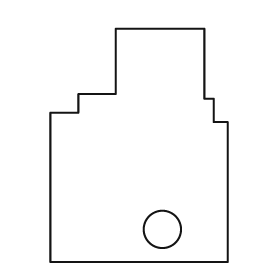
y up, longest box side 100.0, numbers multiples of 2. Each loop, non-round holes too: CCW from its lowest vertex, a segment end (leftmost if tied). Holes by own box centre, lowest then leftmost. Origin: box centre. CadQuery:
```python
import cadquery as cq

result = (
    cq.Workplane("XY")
    .moveTo(-38.0, -50.0)
    .lineTo(38.0, -50.0)
    .lineTo(38.0, 10.0)
    .lineTo(32.0, 10.0)
    .lineTo(32.0, 20.0)
    .lineTo(28.0, 20.0)
    .lineTo(28.0, 50.0)
    .lineTo(-10.0, 50.0)
    .lineTo(-10.0, 22.0)
    .lineTo(-26.0, 22.0)
    .lineTo(-26.0, 14.0)
    .lineTo(-38.0, 14.0)
    .close()
    .moveTo(10.0, -36.0)
    .circle(8.0)
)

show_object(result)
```